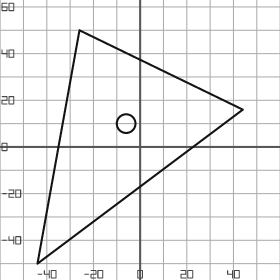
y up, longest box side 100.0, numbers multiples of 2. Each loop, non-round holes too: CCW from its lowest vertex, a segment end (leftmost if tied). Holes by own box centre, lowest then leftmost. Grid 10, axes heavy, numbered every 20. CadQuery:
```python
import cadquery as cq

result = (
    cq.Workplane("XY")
    .moveTo(-44.0, -50.0)
    .lineTo(44.0, 16.0)
    .lineTo(-26.0, 50.0)
    .close()
    .moveTo(-6.0, 10.0)
    .circle(4.0)
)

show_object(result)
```